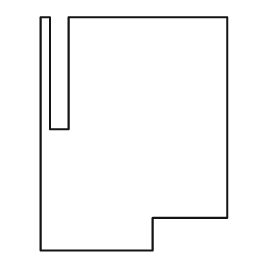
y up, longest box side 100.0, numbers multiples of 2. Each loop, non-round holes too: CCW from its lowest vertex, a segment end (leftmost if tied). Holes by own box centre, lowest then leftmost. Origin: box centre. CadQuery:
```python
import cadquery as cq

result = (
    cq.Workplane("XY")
    .moveTo(-40.0, -50.0)
    .lineTo(8.0, -50.0)
    .lineTo(8.0, -36.0)
    .lineTo(40.0, -36.0)
    .lineTo(40.0, 50.0)
    .lineTo(-28.0, 50.0)
    .lineTo(-28.0, 2.0)
    .lineTo(-36.0, 2.0)
    .lineTo(-36.0, 50.0)
    .lineTo(-40.0, 50.0)
    .close()
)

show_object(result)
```